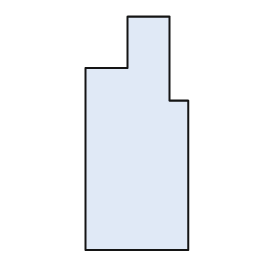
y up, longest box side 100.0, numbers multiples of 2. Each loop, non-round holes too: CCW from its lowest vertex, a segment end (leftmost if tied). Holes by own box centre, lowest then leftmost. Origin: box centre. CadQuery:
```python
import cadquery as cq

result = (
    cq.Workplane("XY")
    .moveTo(-22.0, -50.0)
    .lineTo(22.0, -50.0)
    .lineTo(22.0, 14.0)
    .lineTo(14.0, 14.0)
    .lineTo(14.0, 50.0)
    .lineTo(-4.0, 50.0)
    .lineTo(-4.0, 28.0)
    .lineTo(-22.0, 28.0)
    .close()
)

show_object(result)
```